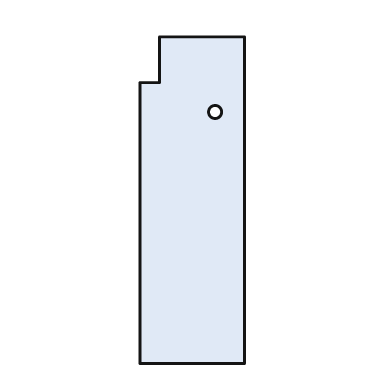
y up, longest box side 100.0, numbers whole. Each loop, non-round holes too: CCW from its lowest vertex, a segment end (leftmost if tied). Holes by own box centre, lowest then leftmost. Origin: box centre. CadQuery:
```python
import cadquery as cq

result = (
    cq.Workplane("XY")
    .moveTo(-16.0, -50.0)
    .lineTo(16.0, -50.0)
    .lineTo(16.0, 50.0)
    .lineTo(-10.0, 50.0)
    .lineTo(-10.0, 36.0)
    .lineTo(-16.0, 36.0)
    .close()
    .moveTo(7.0, 27.0)
    .circle(2.0)
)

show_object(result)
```